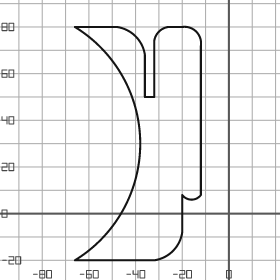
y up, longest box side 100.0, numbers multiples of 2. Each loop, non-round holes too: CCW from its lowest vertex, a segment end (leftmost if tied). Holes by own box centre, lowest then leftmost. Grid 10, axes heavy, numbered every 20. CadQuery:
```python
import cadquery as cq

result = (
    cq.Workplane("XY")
    .moveTo(-66.0, -20.0)
    .lineTo(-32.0, -20.0)
    .threePointArc((-24.0, -16.0), (-20.0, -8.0))
    .lineTo(-20.0, 8.0)
    .threePointArc((-16.0, 6.0), (-12.0, 8.0))
    .lineTo(-12.0, 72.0)
    .threePointArc((-14.0, 78.0), (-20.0, 80.0))
    .lineTo(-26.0, 80.0)
    .threePointArc((-30.0, 78.0), (-32.0, 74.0))
    .lineTo(-32.0, 50.0)
    .lineTo(-36.0, 50.0)
    .lineTo(-36.0, 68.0)
    .threePointArc((-40.0, 76.0), (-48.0, 80.0))
    .lineTo(-66.0, 80.0)
    .threePointArc((-38.0, 30.0), (-66.0, -20.0))
    .close()
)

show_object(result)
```